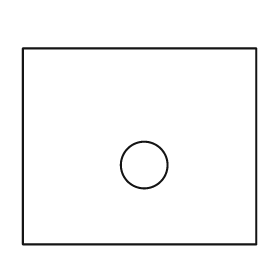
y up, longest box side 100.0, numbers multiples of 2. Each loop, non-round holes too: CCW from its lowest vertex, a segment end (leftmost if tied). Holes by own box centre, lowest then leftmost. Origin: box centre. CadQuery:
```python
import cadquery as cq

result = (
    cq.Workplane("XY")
    .moveTo(-50.0, -42.0)
    .lineTo(50.0, -42.0)
    .lineTo(50.0, 42.0)
    .lineTo(-50.0, 42.0)
    .close()
    .moveTo(2.0, -8.0)
    .circle(10.0)
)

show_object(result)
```